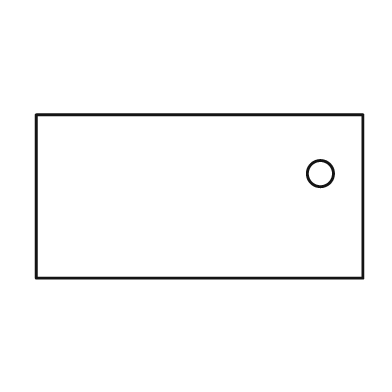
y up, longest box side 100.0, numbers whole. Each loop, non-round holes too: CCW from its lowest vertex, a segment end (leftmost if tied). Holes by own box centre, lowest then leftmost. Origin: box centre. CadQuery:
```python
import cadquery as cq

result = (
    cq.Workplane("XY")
    .moveTo(-50.0, -25.0)
    .lineTo(50.0, -25.0)
    .lineTo(50.0, 25.0)
    .lineTo(-50.0, 25.0)
    .close()
    .moveTo(37.0, 7.0)
    .circle(4.0)
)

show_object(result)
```